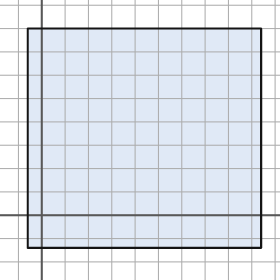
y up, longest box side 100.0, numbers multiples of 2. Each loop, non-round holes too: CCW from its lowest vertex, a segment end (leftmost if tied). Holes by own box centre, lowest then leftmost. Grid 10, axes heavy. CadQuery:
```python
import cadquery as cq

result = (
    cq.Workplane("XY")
    .moveTo(-6.0, -14.0)
    .lineTo(94.0, -14.0)
    .lineTo(94.0, 80.0)
    .lineTo(-6.0, 80.0)
    .close()
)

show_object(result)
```